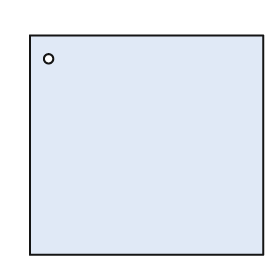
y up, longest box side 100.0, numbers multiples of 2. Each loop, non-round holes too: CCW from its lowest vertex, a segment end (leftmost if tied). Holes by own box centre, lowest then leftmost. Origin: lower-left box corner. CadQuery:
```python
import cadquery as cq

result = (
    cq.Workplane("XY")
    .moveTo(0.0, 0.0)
    .lineTo(100.0, 0.0)
    .lineTo(100.0, 94.0)
    .lineTo(0.0, 94.0)
    .close()
    .moveTo(8.0, 84.0)
    .circle(2.0)
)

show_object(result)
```